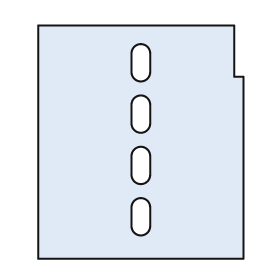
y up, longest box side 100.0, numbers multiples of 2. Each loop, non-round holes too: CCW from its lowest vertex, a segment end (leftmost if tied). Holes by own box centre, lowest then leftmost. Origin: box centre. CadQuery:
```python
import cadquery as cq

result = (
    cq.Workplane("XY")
    .moveTo(-44.0, -50.0)
    .lineTo(44.0, -50.0)
    .lineTo(44.0, 28.0)
    .lineTo(40.0, 28.0)
    .lineTo(40.0, 50.0)
    .lineTo(-44.0, 50.0)
    .close()
    .moveTo(-4.0, -36.0)
    .threePointArc((0.0, -40.0), (4.0, -36.0))
    .lineTo(4.0, -28.0)
    .threePointArc((0.0, -24.0), (-4.0, -28.0))
    .close()
    .moveTo(-4.0, -14.0)
    .threePointArc((0.0, -18.0), (4.0, -14.0))
    .lineTo(4.0, -6.0)
    .threePointArc((0.0, -2.0), (-4.0, -6.0))
    .close()
    .moveTo(-4.0, 8.0)
    .threePointArc((0.0, 4.0), (4.0, 8.0))
    .lineTo(4.0, 16.0)
    .threePointArc((0.0, 20.0), (-4.0, 16.0))
    .close()
    .moveTo(-4.0, 30.0)
    .threePointArc((0.0, 26.0), (4.0, 30.0))
    .lineTo(4.0, 38.0)
    .threePointArc((0.0, 42.0), (-4.0, 38.0))
    .close()
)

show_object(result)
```